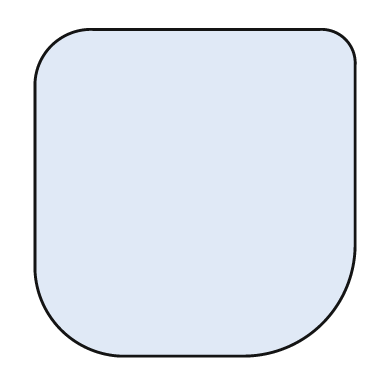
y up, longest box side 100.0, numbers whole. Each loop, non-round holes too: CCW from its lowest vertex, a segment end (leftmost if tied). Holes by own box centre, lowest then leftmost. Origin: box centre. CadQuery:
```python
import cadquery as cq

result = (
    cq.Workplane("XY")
    .moveTo(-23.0, -50.0)
    .lineTo(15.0, -50.0)
    .threePointArc((39.0, -40.0), (49.0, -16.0))
    .lineTo(49.0, 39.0)
    .threePointArc((46.0, 47.0), (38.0, 50.0))
    .lineTo(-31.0, 50.0)
    .threePointArc((-44.0, 45.0), (-49.0, 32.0))
    .lineTo(-49.0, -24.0)
    .threePointArc((-41.0, -42.0), (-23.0, -50.0))
    .close()
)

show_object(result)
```